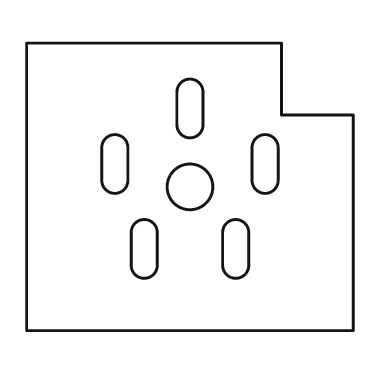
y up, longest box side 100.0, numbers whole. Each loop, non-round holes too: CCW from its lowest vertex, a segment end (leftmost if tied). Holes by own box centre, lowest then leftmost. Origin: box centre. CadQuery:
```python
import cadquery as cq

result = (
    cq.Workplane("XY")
    .moveTo(-50.0, -44.0)
    .lineTo(50.0, -44.0)
    .lineTo(50.0, 22.0)
    .lineTo(28.0, 22.0)
    .lineTo(28.0, 44.0)
    .lineTo(-50.0, 44.0)
    .close()
    .moveTo(-18.0, -24.0)
    .threePointArc((-14.0, -28.0), (-10.0, -24.0))
    .lineTo(-10.0, -14.0)
    .threePointArc((-14.0, -10.0), (-18.0, -14.0))
    .close()
    .moveTo(10.0, -24.0)
    .threePointArc((14.0, -28.0), (18.0, -24.0))
    .lineTo(18.0, -14.0)
    .threePointArc((14.0, -10.0), (10.0, -14.0))
    .close()
    .moveTo(0.0, 0.0)
    .circle(7.0)
    .moveTo(-27.0, 2.0)
    .threePointArc((-23.0, -2.0), (-19.0, 2.0))
    .lineTo(-19.0, 12.0)
    .threePointArc((-23.0, 16.0), (-27.0, 12.0))
    .close()
    .moveTo(19.0, 2.0)
    .threePointArc((23.0, -2.0), (27.0, 2.0))
    .lineTo(27.0, 12.0)
    .threePointArc((23.0, 16.0), (19.0, 12.0))
    .close()
    .moveTo(-4.0, 19.0)
    .threePointArc((0.0, 15.0), (4.0, 19.0))
    .lineTo(4.0, 29.0)
    .threePointArc((0.0, 33.0), (-4.0, 29.0))
    .close()
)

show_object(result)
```